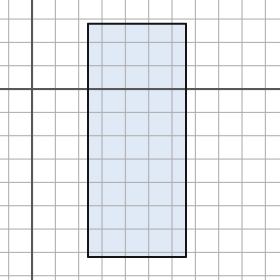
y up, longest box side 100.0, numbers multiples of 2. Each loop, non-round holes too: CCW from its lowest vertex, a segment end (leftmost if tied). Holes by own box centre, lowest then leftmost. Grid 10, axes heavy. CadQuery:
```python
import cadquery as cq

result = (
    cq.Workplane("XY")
    .moveTo(24.0, -72.0)
    .lineTo(66.0, -72.0)
    .lineTo(66.0, 28.0)
    .lineTo(24.0, 28.0)
    .close()
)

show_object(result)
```